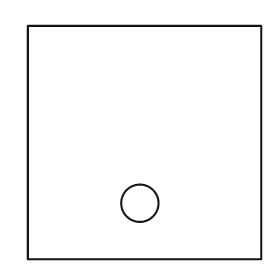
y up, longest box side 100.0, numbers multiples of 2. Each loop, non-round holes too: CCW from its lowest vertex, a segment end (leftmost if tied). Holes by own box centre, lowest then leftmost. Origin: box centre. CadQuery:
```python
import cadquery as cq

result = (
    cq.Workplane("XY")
    .moveTo(-50.0, -50.0)
    .lineTo(50.0, -50.0)
    .lineTo(50.0, 50.0)
    .lineTo(-50.0, 50.0)
    .close()
    .moveTo(-2.0, -26.0)
    .circle(8.0)
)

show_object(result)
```